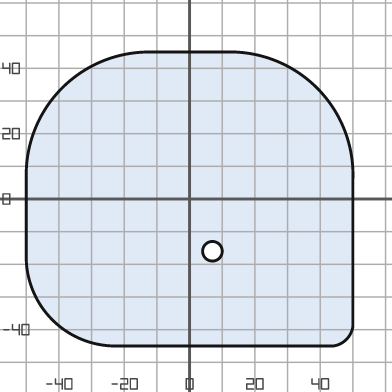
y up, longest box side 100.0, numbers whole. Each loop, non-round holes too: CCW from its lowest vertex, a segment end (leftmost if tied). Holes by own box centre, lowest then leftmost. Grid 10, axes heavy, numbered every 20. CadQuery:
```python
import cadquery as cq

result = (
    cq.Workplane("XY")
    .moveTo(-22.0, -45.0)
    .lineTo(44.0, -45.0)
    .threePointArc((48.0, -43.0), (50.0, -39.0))
    .lineTo(50.0, 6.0)
    .threePointArc((39.0, 34.0), (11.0, 45.0))
    .lineTo(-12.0, 45.0)
    .threePointArc((-39.0, 34.0), (-50.0, 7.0))
    .lineTo(-50.0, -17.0)
    .threePointArc((-42.0, -37.0), (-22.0, -45.0))
    .close()
    .moveTo(7.0, -16.0)
    .circle(3.0)
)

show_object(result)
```